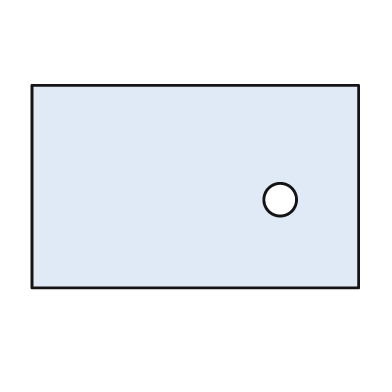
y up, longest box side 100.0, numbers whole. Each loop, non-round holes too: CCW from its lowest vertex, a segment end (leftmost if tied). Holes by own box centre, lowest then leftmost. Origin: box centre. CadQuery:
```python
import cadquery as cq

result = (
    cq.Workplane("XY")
    .moveTo(-50.0, -31.0)
    .lineTo(50.0, -31.0)
    .lineTo(50.0, 31.0)
    .lineTo(-50.0, 31.0)
    .close()
    .moveTo(26.0, -4.0)
    .circle(5.0)
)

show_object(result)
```